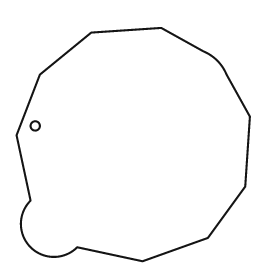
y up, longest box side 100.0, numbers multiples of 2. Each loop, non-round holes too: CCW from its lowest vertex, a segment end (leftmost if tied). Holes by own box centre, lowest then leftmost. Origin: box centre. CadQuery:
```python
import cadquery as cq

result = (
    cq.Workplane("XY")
    .moveTo(4.0, -50.0)
    .lineTo(32.0, -40.0)
    .lineTo(48.0, -18.0)
    .lineTo(50.0, 12.0)
    .lineTo(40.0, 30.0)
    .threePointArc((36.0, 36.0), (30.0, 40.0))
    .lineTo(12.0, 50.0)
    .lineTo(-18.0, 48.0)
    .lineTo(-40.0, 30.0)
    .lineTo(-50.0, 4.0)
    .lineTo(-44.0, -24.0)
    .threePointArc((-44.0, -44.0), (-24.0, -44.0))
    .close()
    .moveTo(-42.0, 8.0)
    .circle(2.0)
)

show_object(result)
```